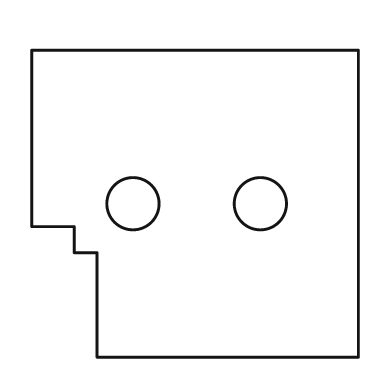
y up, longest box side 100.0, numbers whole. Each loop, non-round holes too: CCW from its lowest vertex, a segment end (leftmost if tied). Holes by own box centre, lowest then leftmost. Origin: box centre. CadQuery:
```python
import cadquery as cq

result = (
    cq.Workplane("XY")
    .moveTo(-30.0, -47.0)
    .lineTo(50.0, -47.0)
    .lineTo(50.0, 47.0)
    .lineTo(-50.0, 47.0)
    .lineTo(-50.0, -7.0)
    .lineTo(-37.0, -7.0)
    .lineTo(-37.0, -15.0)
    .lineTo(-30.0, -15.0)
    .close()
    .moveTo(-19.0, 0.0)
    .circle(8.0)
    .moveTo(20.0, 0.0)
    .circle(8.0)
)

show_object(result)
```